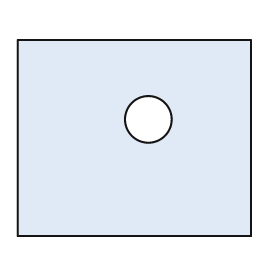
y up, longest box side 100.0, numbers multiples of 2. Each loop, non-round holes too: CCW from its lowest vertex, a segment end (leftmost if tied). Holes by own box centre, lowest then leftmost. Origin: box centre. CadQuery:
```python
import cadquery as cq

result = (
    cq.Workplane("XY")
    .moveTo(-50.0, -42.0)
    .lineTo(50.0, -42.0)
    .lineTo(50.0, 42.0)
    .lineTo(-50.0, 42.0)
    .close()
    .moveTo(6.0, 8.0)
    .circle(10.0)
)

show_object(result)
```